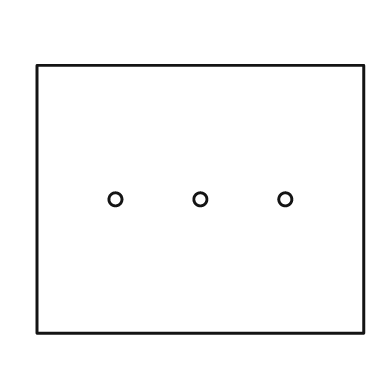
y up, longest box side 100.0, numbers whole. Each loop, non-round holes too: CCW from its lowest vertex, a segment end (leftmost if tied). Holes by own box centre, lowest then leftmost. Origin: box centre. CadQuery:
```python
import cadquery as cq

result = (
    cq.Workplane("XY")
    .moveTo(-50.0, -41.0)
    .lineTo(50.0, -41.0)
    .lineTo(50.0, 41.0)
    .lineTo(-50.0, 41.0)
    .close()
    .moveTo(-26.0, 0.0)
    .circle(2.0)
    .moveTo(0.0, 0.0)
    .circle(2.0)
    .moveTo(26.0, 0.0)
    .circle(2.0)
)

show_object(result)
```